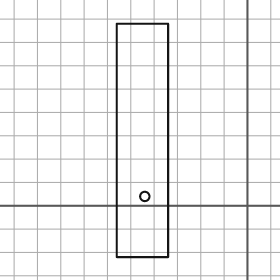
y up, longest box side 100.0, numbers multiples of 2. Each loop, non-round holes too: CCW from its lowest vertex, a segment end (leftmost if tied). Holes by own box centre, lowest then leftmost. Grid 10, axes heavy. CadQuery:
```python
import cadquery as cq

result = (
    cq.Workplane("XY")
    .moveTo(-56.0, -22.0)
    .lineTo(-34.0, -22.0)
    .lineTo(-34.0, 78.0)
    .lineTo(-56.0, 78.0)
    .close()
    .moveTo(-44.0, 4.0)
    .circle(2.0)
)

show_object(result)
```